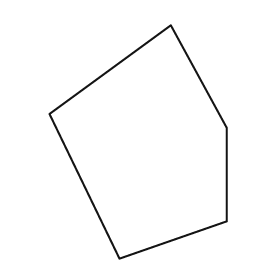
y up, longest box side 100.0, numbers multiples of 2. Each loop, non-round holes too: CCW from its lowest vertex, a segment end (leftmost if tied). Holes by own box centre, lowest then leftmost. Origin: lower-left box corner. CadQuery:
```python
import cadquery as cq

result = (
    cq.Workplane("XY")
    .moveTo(30.0, 0.0)
    .lineTo(76.0, 16.0)
    .lineTo(76.0, 56.0)
    .lineTo(52.0, 100.0)
    .lineTo(0.0, 62.0)
    .close()
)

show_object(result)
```